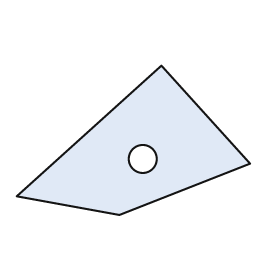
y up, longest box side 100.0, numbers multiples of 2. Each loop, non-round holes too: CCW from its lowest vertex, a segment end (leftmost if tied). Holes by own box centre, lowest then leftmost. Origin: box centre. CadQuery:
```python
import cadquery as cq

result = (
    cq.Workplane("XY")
    .moveTo(-6.0, -32.0)
    .lineTo(50.0, -10.0)
    .lineTo(12.0, 32.0)
    .lineTo(-50.0, -24.0)
    .close()
    .moveTo(4.0, -8.0)
    .circle(6.0)
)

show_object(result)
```